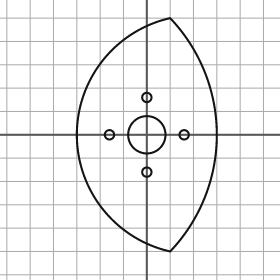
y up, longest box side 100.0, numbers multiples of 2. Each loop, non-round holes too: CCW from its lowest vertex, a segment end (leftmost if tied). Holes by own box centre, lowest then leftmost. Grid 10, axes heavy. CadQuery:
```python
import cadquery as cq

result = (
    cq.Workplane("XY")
    .moveTo(10.0, -50.0)
    .threePointArc((30.0, 0.0), (10.0, 50.0))
    .threePointArc((-30.0, 0.0), (10.0, -50.0))
    .close()
    .moveTo(0.0, -16.0)
    .circle(2.0)
    .moveTo(-16.0, 0.0)
    .circle(2.0)
    .moveTo(0.0, 0.0)
    .circle(8.0)
    .moveTo(16.0, 0.0)
    .circle(2.0)
    .moveTo(0.0, 16.0)
    .circle(2.0)
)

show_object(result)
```